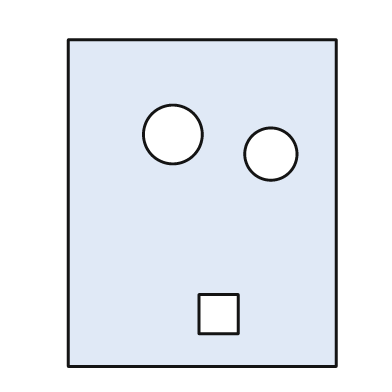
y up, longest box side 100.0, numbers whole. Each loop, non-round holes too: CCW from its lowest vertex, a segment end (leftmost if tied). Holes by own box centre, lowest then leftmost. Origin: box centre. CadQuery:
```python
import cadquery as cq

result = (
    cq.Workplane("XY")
    .moveTo(-41.0, -50.0)
    .lineTo(41.0, -50.0)
    .lineTo(41.0, 50.0)
    .lineTo(-41.0, 50.0)
    .close()
    .moveTo(-1.0, -40.0)
    .lineTo(11.0, -40.0)
    .lineTo(11.0, -28.0)
    .lineTo(-1.0, -28.0)
    .close()
    .moveTo(21.0, 15.0)
    .circle(8.0)
    .moveTo(-9.0, 21.0)
    .circle(9.0)
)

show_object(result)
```